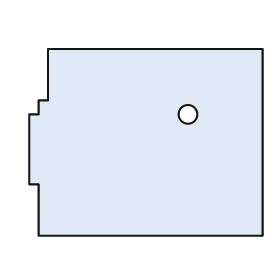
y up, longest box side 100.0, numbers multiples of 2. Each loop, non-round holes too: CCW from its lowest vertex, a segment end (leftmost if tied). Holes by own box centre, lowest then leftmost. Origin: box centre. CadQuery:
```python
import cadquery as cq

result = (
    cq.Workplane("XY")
    .moveTo(-46.0, -40.0)
    .lineTo(50.0, -40.0)
    .lineTo(50.0, 40.0)
    .lineTo(-42.0, 40.0)
    .lineTo(-42.0, 18.0)
    .lineTo(-46.0, 18.0)
    .lineTo(-46.0, 12.0)
    .lineTo(-50.0, 12.0)
    .lineTo(-50.0, -18.0)
    .lineTo(-46.0, -18.0)
    .close()
    .moveTo(18.0, 12.0)
    .circle(4.0)
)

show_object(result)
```